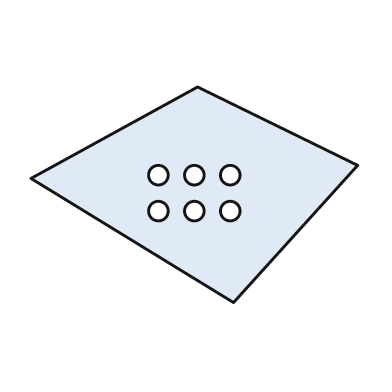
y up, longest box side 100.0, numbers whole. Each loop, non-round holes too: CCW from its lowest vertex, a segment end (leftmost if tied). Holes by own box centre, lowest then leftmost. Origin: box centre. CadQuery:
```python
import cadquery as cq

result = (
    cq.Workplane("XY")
    .moveTo(12.0, -33.0)
    .lineTo(50.0, 9.0)
    .lineTo(1.0, 33.0)
    .lineTo(-50.0, 5.0)
    .close()
    .moveTo(-11.0, -5.0)
    .circle(3.0)
    .moveTo(0.0, -5.0)
    .circle(3.0)
    .moveTo(11.0, -5.0)
    .circle(3.0)
    .moveTo(-11.0, 6.0)
    .circle(3.0)
    .moveTo(0.0, 6.0)
    .circle(3.0)
    .moveTo(11.0, 6.0)
    .circle(3.0)
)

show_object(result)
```